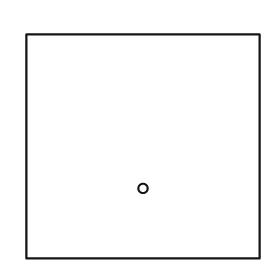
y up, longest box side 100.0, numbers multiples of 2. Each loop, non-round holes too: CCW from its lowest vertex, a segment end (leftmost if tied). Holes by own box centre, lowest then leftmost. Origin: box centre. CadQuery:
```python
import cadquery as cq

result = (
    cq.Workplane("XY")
    .moveTo(-50.0, -48.0)
    .lineTo(50.0, -48.0)
    .lineTo(50.0, 48.0)
    .lineTo(-50.0, 48.0)
    .close()
    .moveTo(0.0, -18.0)
    .circle(2.0)
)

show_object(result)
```